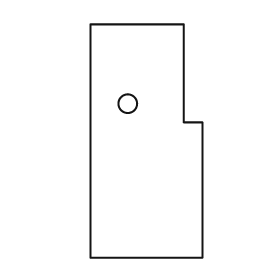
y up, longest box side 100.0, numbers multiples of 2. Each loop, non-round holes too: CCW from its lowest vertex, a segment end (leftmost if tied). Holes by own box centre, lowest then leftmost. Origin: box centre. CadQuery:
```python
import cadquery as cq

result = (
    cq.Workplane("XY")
    .moveTo(-24.0, -50.0)
    .lineTo(24.0, -50.0)
    .lineTo(24.0, 8.0)
    .lineTo(16.0, 8.0)
    .lineTo(16.0, 50.0)
    .lineTo(-24.0, 50.0)
    .close()
    .moveTo(-8.0, 16.0)
    .circle(4.0)
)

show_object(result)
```